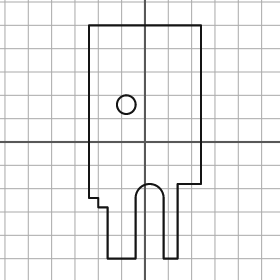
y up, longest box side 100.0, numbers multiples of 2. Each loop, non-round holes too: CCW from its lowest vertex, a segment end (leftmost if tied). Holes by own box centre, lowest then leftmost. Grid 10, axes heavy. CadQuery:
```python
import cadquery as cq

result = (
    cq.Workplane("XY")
    .moveTo(-16.0, -50.0)
    .lineTo(-4.0, -50.0)
    .lineTo(-4.0, -24.0)
    .threePointArc((2.0, -18.0), (8.0, -24.0))
    .lineTo(8.0, -50.0)
    .lineTo(14.0, -50.0)
    .lineTo(14.0, -18.0)
    .lineTo(24.0, -18.0)
    .lineTo(24.0, 50.0)
    .lineTo(-24.0, 50.0)
    .lineTo(-24.0, -24.0)
    .lineTo(-20.0, -24.0)
    .lineTo(-20.0, -28.0)
    .lineTo(-16.0, -28.0)
    .close()
    .moveTo(-8.0, 16.0)
    .circle(4.0)
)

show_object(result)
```